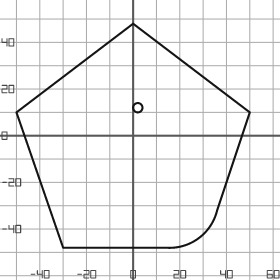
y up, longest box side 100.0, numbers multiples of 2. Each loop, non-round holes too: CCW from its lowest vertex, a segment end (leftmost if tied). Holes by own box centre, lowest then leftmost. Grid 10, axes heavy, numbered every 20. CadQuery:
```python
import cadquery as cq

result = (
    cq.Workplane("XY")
    .moveTo(-30.0, -48.0)
    .lineTo(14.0, -48.0)
    .threePointArc((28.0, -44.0), (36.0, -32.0))
    .lineTo(50.0, 10.0)
    .lineTo(0.0, 48.0)
    .lineTo(-50.0, 10.0)
    .close()
    .moveTo(2.0, 12.0)
    .circle(2.0)
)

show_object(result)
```